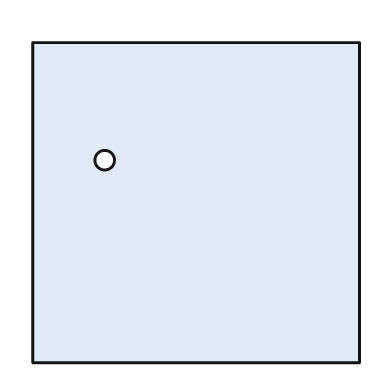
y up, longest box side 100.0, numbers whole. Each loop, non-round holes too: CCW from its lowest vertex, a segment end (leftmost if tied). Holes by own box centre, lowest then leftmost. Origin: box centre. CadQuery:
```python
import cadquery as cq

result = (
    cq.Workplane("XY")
    .moveTo(-50.0, -49.0)
    .lineTo(50.0, -49.0)
    .lineTo(50.0, 49.0)
    .lineTo(-50.0, 49.0)
    .close()
    .moveTo(-28.0, 13.0)
    .circle(3.0)
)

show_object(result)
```